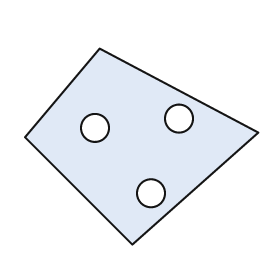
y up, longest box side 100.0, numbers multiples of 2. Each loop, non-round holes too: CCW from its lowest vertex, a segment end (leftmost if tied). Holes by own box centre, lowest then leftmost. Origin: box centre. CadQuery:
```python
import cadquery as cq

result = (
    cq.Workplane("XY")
    .moveTo(-4.0, -42.0)
    .lineTo(50.0, 6.0)
    .lineTo(-18.0, 42.0)
    .lineTo(-50.0, 4.0)
    .close()
    .moveTo(4.0, -20.0)
    .circle(6.0)
    .moveTo(-20.0, 8.0)
    .circle(6.0)
    .moveTo(16.0, 12.0)
    .circle(6.0)
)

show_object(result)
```